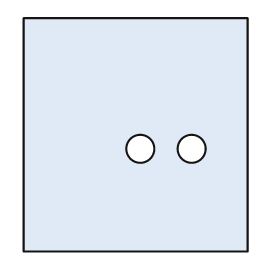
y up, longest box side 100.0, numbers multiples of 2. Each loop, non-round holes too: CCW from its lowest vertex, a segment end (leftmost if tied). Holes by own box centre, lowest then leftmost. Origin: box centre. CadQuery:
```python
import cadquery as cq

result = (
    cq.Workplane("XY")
    .moveTo(-48.0, -50.0)
    .lineTo(48.0, -50.0)
    .lineTo(48.0, 50.0)
    .lineTo(-48.0, 50.0)
    .close()
    .moveTo(2.0, -6.0)
    .circle(6.0)
    .moveTo(24.0, -6.0)
    .circle(6.0)
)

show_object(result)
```